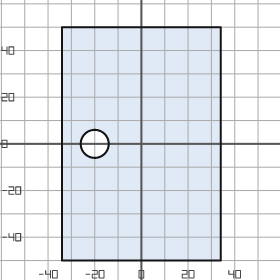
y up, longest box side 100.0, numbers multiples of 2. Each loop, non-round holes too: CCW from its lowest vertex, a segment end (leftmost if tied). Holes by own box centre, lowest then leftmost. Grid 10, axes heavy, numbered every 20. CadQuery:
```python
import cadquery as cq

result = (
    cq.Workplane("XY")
    .moveTo(-34.0, -50.0)
    .lineTo(34.0, -50.0)
    .lineTo(34.0, 50.0)
    .lineTo(-34.0, 50.0)
    .close()
    .moveTo(-20.0, 0.0)
    .circle(6.0)
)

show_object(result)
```